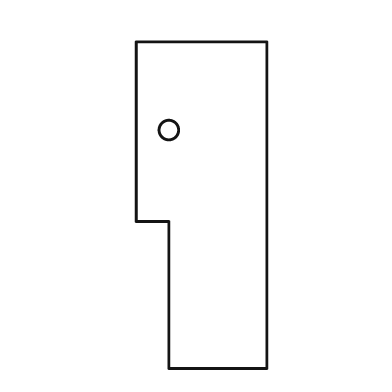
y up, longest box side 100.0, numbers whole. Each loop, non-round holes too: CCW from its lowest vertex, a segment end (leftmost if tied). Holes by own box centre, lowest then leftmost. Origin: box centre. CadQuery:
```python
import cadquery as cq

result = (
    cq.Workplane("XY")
    .moveTo(-10.0, -50.0)
    .lineTo(20.0, -50.0)
    .lineTo(20.0, 50.0)
    .lineTo(-20.0, 50.0)
    .lineTo(-20.0, -5.0)
    .lineTo(-10.0, -5.0)
    .close()
    .moveTo(-10.0, 23.0)
    .circle(3.0)
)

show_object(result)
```